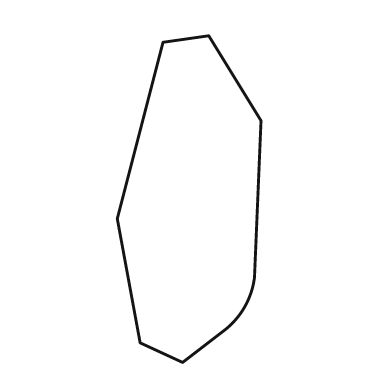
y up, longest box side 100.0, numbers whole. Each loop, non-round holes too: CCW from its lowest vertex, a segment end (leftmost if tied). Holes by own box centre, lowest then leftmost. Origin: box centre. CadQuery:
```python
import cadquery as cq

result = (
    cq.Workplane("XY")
    .moveTo(-2.0, -50.0)
    .lineTo(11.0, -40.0)
    .threePointArc((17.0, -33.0), (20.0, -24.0))
    .lineTo(22.0, 24.0)
    .lineTo(6.0, 50.0)
    .lineTo(-8.0, 48.0)
    .lineTo(-22.0, -6.0)
    .lineTo(-15.0, -44.0)
    .close()
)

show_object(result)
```